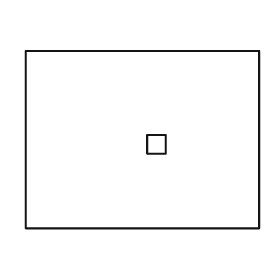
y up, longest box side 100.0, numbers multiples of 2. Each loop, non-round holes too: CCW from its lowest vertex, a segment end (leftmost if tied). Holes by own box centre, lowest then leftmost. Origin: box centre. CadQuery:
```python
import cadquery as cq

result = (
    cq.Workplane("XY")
    .moveTo(-50.0, -38.0)
    .lineTo(50.0, -38.0)
    .lineTo(50.0, 38.0)
    .lineTo(-50.0, 38.0)
    .close()
    .moveTo(2.0, -6.0)
    .lineTo(10.0, -6.0)
    .lineTo(10.0, 2.0)
    .lineTo(2.0, 2.0)
    .close()
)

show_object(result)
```